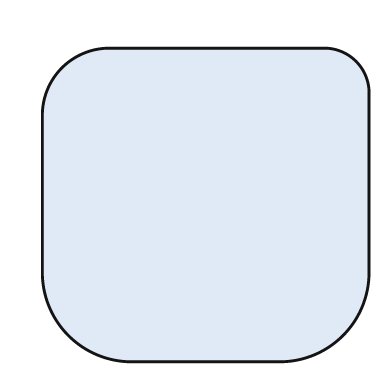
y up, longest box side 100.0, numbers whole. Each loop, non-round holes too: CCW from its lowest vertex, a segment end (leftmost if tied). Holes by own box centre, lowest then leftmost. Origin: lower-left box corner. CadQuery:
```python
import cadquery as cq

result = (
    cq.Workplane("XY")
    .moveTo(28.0, 0.0)
    .lineTo(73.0, 0.0)
    .threePointArc((92.0, 8.0), (100.0, 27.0))
    .lineTo(100.0, 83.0)
    .threePointArc((96.0, 92.0), (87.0, 96.0))
    .lineTo(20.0, 96.0)
    .threePointArc((6.0, 90.0), (0.0, 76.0))
    .lineTo(0.0, 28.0)
    .threePointArc((8.0, 8.0), (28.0, 0.0))
    .close()
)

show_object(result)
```